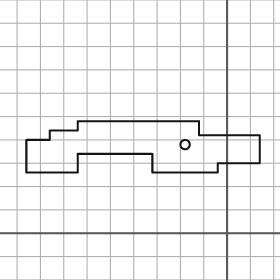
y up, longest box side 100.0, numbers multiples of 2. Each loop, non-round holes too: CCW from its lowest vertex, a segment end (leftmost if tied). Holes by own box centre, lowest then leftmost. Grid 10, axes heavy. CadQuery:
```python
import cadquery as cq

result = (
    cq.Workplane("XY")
    .moveTo(-86.0, 26.0)
    .lineTo(-64.0, 26.0)
    .lineTo(-64.0, 34.0)
    .lineTo(-32.0, 34.0)
    .lineTo(-32.0, 26.0)
    .lineTo(-4.0, 26.0)
    .lineTo(-4.0, 30.0)
    .lineTo(14.0, 30.0)
    .lineTo(14.0, 42.0)
    .lineTo(-12.0, 42.0)
    .lineTo(-12.0, 48.0)
    .lineTo(-64.0, 48.0)
    .lineTo(-64.0, 44.0)
    .lineTo(-76.0, 44.0)
    .lineTo(-76.0, 40.0)
    .lineTo(-86.0, 40.0)
    .close()
    .moveTo(-18.0, 38.0)
    .circle(2.0)
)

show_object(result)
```